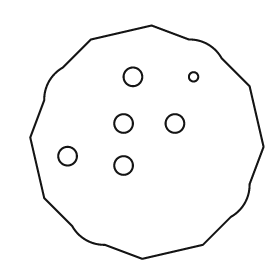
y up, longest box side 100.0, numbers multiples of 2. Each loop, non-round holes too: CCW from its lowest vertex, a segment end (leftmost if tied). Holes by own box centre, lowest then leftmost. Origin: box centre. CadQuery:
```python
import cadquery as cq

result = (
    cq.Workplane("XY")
    .moveTo(-2.0, -50.0)
    .lineTo(24.0, -44.0)
    .lineTo(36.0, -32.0)
    .threePointArc((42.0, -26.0), (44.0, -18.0))
    .lineTo(50.0, -2.0)
    .lineTo(44.0, 24.0)
    .lineTo(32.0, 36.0)
    .threePointArc((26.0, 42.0), (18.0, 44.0))
    .lineTo(2.0, 50.0)
    .lineTo(-24.0, 44.0)
    .lineTo(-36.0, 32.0)
    .threePointArc((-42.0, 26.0), (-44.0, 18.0))
    .lineTo(-50.0, 2.0)
    .lineTo(-44.0, -24.0)
    .lineTo(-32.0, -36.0)
    .threePointArc((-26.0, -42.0), (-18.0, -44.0))
    .close()
    .moveTo(-10.0, -10.0)
    .circle(4.0)
    .moveTo(-34.0, -6.0)
    .circle(4.0)
    .moveTo(-10.0, 8.0)
    .circle(4.0)
    .moveTo(12.0, 8.0)
    .circle(4.0)
    .moveTo(-6.0, 28.0)
    .circle(4.0)
    .moveTo(20.0, 28.0)
    .circle(2.0)
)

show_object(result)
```